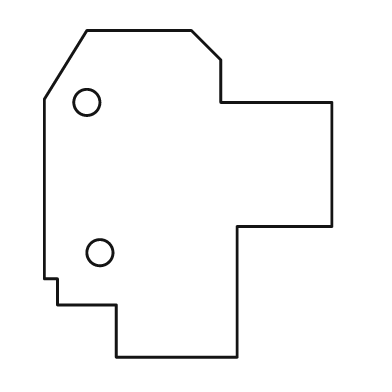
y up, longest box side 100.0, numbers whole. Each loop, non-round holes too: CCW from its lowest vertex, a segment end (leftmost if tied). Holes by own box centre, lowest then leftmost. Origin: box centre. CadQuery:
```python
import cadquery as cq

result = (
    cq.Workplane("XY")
    .moveTo(-22.0, -50.0)
    .lineTo(15.0, -50.0)
    .lineTo(15.0, -10.0)
    .lineTo(44.0, -10.0)
    .lineTo(44.0, 28.0)
    .lineTo(10.0, 28.0)
    .lineTo(10.0, 41.0)
    .lineTo(1.0, 50.0)
    .lineTo(-31.0, 50.0)
    .lineTo(-44.0, 29.0)
    .lineTo(-44.0, -26.0)
    .lineTo(-40.0, -26.0)
    .lineTo(-40.0, -34.0)
    .lineTo(-22.0, -34.0)
    .close()
    .moveTo(-27.0, -18.0)
    .circle(4.0)
    .moveTo(-31.0, 28.0)
    .circle(4.0)
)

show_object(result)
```